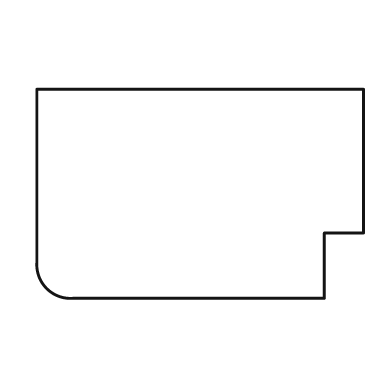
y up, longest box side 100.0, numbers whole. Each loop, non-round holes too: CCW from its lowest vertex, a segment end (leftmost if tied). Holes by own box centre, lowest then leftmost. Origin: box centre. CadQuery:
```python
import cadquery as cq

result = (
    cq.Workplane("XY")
    .moveTo(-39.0, -32.0)
    .lineTo(38.0, -32.0)
    .lineTo(38.0, -12.0)
    .lineTo(50.0, -12.0)
    .lineTo(50.0, 32.0)
    .lineTo(-50.0, 32.0)
    .lineTo(-50.0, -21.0)
    .threePointArc((-47.0, -29.0), (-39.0, -32.0))
    .close()
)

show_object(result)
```